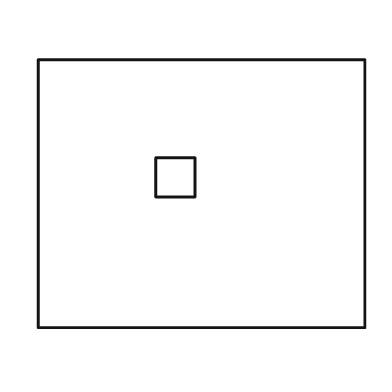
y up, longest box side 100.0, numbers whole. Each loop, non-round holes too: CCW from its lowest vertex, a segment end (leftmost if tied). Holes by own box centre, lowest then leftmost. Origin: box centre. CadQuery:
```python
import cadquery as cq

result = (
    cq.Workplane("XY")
    .moveTo(-50.0, -41.0)
    .lineTo(50.0, -41.0)
    .lineTo(50.0, 41.0)
    .lineTo(-50.0, 41.0)
    .close()
    .moveTo(-14.0, -1.0)
    .lineTo(-2.0, -1.0)
    .lineTo(-2.0, 11.0)
    .lineTo(-14.0, 11.0)
    .close()
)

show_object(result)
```